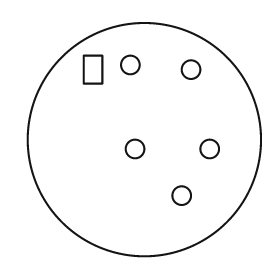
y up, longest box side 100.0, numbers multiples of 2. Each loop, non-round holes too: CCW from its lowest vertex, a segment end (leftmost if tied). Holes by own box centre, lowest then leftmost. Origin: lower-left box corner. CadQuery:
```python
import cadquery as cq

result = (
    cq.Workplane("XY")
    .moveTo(50.0, 50.0)
    .circle(50.0)
    .moveTo(66.0, 26.0)
    .circle(4.0)
    .moveTo(46.0, 46.0)
    .circle(4.0)
    .moveTo(78.0, 46.0)
    .circle(4.0)
    .moveTo(24.0, 74.0)
    .lineTo(32.0, 74.0)
    .lineTo(32.0, 86.0)
    .lineTo(24.0, 86.0)
    .close()
    .moveTo(70.0, 80.0)
    .circle(4.0)
    .moveTo(44.0, 82.0)
    .circle(4.0)
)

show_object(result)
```